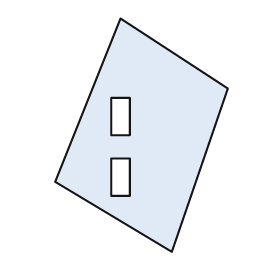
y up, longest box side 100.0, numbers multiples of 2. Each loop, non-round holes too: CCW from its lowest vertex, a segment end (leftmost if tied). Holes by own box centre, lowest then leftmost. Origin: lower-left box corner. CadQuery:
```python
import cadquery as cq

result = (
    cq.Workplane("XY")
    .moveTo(50.0, 0.0)
    .lineTo(74.0, 70.0)
    .lineTo(28.0, 100.0)
    .lineTo(0.0, 30.0)
    .close()
    .moveTo(24.0, 24.0)
    .lineTo(32.0, 24.0)
    .lineTo(32.0, 40.0)
    .lineTo(24.0, 40.0)
    .close()
    .moveTo(24.0, 50.0)
    .lineTo(32.0, 50.0)
    .lineTo(32.0, 66.0)
    .lineTo(24.0, 66.0)
    .close()
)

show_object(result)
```